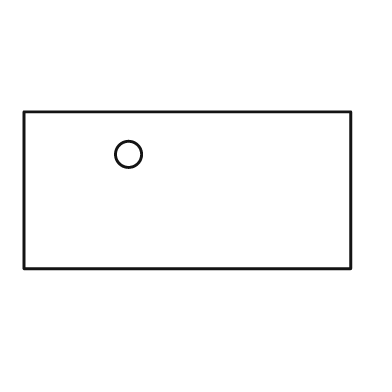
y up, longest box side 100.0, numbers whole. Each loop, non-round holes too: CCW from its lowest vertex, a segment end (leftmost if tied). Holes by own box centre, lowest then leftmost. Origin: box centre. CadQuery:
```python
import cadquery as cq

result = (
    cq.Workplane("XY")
    .moveTo(-50.0, -24.0)
    .lineTo(50.0, -24.0)
    .lineTo(50.0, 24.0)
    .lineTo(-50.0, 24.0)
    .close()
    .moveTo(-18.0, 11.0)
    .circle(4.0)
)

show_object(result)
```